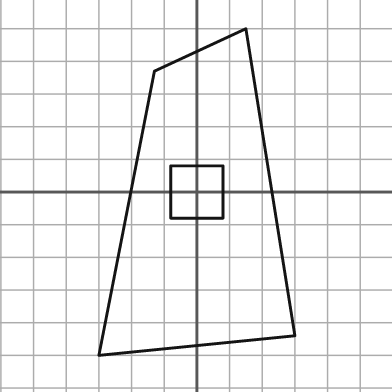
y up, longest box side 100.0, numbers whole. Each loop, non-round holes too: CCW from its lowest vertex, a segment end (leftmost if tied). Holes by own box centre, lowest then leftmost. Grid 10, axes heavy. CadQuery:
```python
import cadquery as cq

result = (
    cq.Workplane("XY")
    .moveTo(-30.0, -50.0)
    .lineTo(30.0, -44.0)
    .lineTo(15.0, 50.0)
    .lineTo(-13.0, 37.0)
    .close()
    .moveTo(-8.0, -8.0)
    .lineTo(8.0, -8.0)
    .lineTo(8.0, 8.0)
    .lineTo(-8.0, 8.0)
    .close()
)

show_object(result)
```